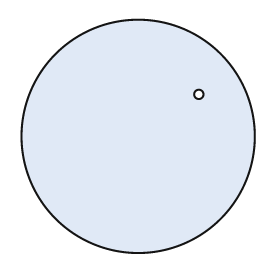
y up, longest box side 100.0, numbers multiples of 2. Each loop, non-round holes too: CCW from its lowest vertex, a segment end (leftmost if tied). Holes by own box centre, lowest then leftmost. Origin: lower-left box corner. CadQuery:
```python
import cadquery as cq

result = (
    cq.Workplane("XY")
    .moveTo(50.0, 50.0)
    .circle(50.0)
    .moveTo(76.0, 68.0)
    .circle(2.0)
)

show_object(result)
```